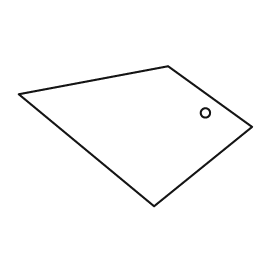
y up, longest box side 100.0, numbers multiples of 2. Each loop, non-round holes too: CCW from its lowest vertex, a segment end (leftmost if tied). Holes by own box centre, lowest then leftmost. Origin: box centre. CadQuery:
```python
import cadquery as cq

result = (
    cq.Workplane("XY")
    .moveTo(8.0, -30.0)
    .lineTo(50.0, 4.0)
    .lineTo(14.0, 30.0)
    .lineTo(-50.0, 18.0)
    .close()
    .moveTo(30.0, 10.0)
    .circle(2.0)
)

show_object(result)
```